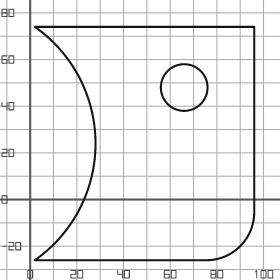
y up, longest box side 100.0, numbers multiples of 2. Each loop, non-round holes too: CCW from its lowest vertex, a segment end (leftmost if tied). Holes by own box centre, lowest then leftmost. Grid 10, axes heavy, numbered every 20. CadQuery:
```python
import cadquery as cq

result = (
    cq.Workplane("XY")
    .moveTo(2.0, -26.0)
    .lineTo(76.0, -26.0)
    .threePointArc((90.0, -20.0), (96.0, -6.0))
    .lineTo(96.0, 74.0)
    .lineTo(2.0, 74.0)
    .threePointArc((28.0, 24.0), (2.0, -26.0))
    .close()
    .moveTo(66.0, 48.0)
    .circle(10.0)
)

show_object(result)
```